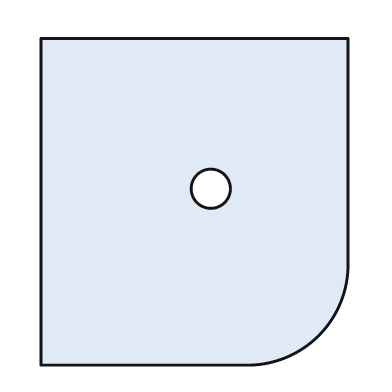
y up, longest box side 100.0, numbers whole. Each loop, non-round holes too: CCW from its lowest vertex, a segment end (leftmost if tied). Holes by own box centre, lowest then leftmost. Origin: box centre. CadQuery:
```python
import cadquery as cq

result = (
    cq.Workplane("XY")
    .moveTo(-47.0, -50.0)
    .lineTo(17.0, -50.0)
    .threePointArc((38.0, -41.0), (47.0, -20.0))
    .lineTo(47.0, 50.0)
    .lineTo(-47.0, 50.0)
    .close()
    .moveTo(5.0, 4.0)
    .circle(6.0)
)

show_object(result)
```